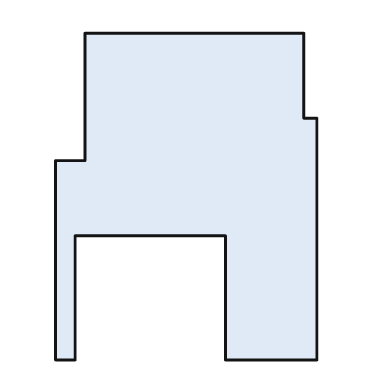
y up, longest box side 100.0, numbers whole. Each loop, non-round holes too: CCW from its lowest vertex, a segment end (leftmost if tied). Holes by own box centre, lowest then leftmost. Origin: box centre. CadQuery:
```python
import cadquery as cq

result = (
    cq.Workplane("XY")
    .moveTo(-40.0, -50.0)
    .lineTo(-34.0, -50.0)
    .lineTo(-34.0, -12.0)
    .lineTo(12.0, -12.0)
    .lineTo(12.0, -50.0)
    .lineTo(40.0, -50.0)
    .lineTo(40.0, 24.0)
    .lineTo(36.0, 24.0)
    .lineTo(36.0, 50.0)
    .lineTo(-31.0, 50.0)
    .lineTo(-31.0, 11.0)
    .lineTo(-40.0, 11.0)
    .close()
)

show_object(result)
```